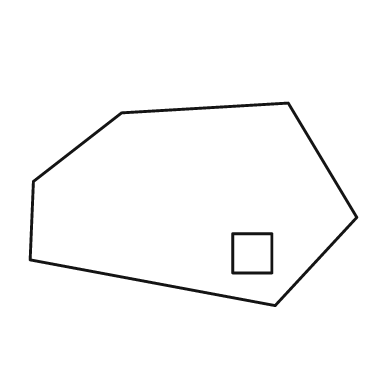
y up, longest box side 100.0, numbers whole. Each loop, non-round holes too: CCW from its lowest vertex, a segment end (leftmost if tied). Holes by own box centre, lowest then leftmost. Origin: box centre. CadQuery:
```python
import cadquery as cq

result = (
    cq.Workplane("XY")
    .moveTo(25.0, -31.0)
    .lineTo(50.0, -4.0)
    .lineTo(29.0, 31.0)
    .lineTo(-22.0, 28.0)
    .lineTo(-49.0, 7.0)
    .lineTo(-50.0, -17.0)
    .close()
    .moveTo(12.0, -21.0)
    .lineTo(24.0, -21.0)
    .lineTo(24.0, -9.0)
    .lineTo(12.0, -9.0)
    .close()
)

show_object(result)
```